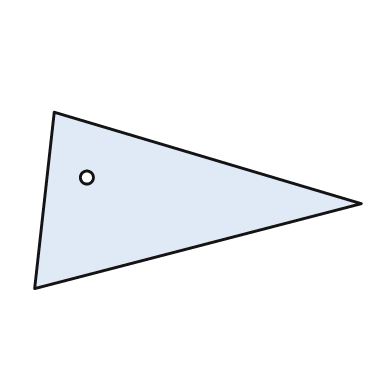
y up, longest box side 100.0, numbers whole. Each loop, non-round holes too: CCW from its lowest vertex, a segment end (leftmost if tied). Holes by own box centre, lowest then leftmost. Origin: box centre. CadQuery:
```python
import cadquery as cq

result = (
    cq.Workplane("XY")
    .moveTo(-50.0, -27.0)
    .lineTo(50.0, -1.0)
    .lineTo(-44.0, 27.0)
    .close()
    .moveTo(-34.0, 7.0)
    .circle(2.0)
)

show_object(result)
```